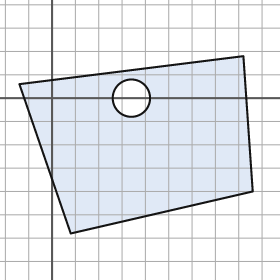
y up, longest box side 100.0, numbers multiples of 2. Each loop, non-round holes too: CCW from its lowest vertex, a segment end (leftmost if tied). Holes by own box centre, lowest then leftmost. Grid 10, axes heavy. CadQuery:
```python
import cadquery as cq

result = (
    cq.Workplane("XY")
    .moveTo(8.0, -58.0)
    .lineTo(86.0, -40.0)
    .lineTo(82.0, 18.0)
    .lineTo(-14.0, 6.0)
    .close()
    .moveTo(34.0, 0.0)
    .circle(8.0)
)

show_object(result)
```